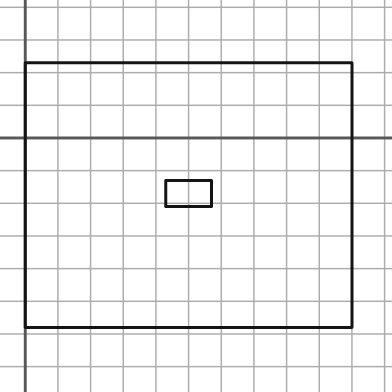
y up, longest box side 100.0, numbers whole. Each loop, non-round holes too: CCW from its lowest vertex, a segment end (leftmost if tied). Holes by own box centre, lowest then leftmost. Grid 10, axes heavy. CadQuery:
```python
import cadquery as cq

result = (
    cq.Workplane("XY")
    .moveTo(0.0, -58.0)
    .lineTo(100.0, -58.0)
    .lineTo(100.0, 23.0)
    .lineTo(0.0, 23.0)
    .close()
    .moveTo(43.0, -21.0)
    .lineTo(57.0, -21.0)
    .lineTo(57.0, -13.0)
    .lineTo(43.0, -13.0)
    .close()
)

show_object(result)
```